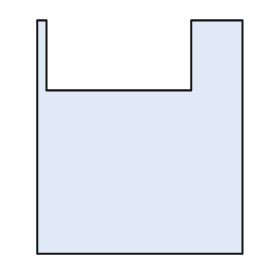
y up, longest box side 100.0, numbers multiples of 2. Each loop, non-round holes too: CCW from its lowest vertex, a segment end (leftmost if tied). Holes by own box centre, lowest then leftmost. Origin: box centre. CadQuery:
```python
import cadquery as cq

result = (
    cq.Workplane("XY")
    .moveTo(-44.0, -50.0)
    .lineTo(44.0, -50.0)
    .lineTo(44.0, 50.0)
    .lineTo(22.0, 50.0)
    .lineTo(22.0, 20.0)
    .lineTo(-40.0, 20.0)
    .lineTo(-40.0, 50.0)
    .lineTo(-44.0, 50.0)
    .close()
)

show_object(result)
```